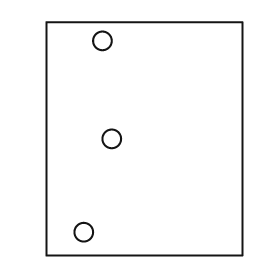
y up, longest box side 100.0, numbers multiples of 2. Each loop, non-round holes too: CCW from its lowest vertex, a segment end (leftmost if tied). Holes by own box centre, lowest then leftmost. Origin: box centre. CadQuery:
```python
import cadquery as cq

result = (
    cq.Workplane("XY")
    .moveTo(-42.0, -50.0)
    .lineTo(42.0, -50.0)
    .lineTo(42.0, 50.0)
    .lineTo(-42.0, 50.0)
    .close()
    .moveTo(-26.0, -40.0)
    .circle(4.0)
    .moveTo(-14.0, 0.0)
    .circle(4.0)
    .moveTo(-18.0, 42.0)
    .circle(4.0)
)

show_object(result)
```